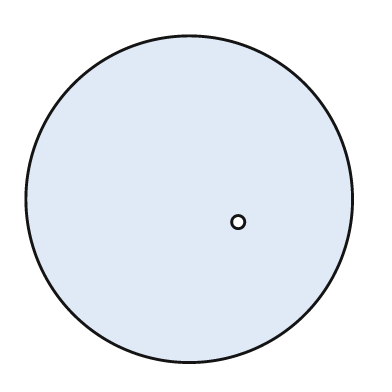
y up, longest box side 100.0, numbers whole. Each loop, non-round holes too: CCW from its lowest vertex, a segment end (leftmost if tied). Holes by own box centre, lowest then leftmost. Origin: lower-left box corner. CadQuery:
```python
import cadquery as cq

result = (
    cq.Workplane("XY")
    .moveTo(50.0, 50.0)
    .circle(50.0)
    .moveTo(65.0, 43.0)
    .circle(2.0)
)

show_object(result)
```